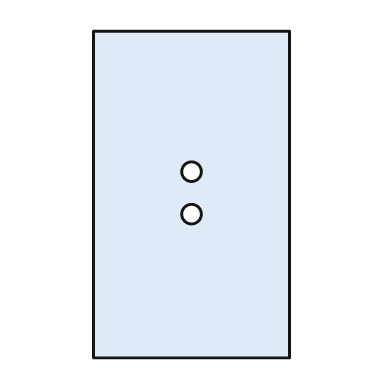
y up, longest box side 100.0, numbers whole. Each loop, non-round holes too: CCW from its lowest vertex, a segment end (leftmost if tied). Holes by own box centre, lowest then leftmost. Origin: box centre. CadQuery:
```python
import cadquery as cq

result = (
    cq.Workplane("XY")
    .moveTo(-30.0, -50.0)
    .lineTo(30.0, -50.0)
    .lineTo(30.0, 50.0)
    .lineTo(-30.0, 50.0)
    .close()
    .moveTo(0.0, -6.0)
    .circle(3.0)
    .moveTo(0.0, 7.0)
    .circle(3.0)
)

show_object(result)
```